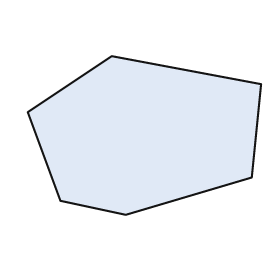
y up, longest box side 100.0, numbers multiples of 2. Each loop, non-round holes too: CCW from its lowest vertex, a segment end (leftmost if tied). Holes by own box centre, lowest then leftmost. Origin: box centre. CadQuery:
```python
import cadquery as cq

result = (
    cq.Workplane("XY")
    .moveTo(-8.0, -34.0)
    .lineTo(46.0, -18.0)
    .lineTo(50.0, 22.0)
    .lineTo(-14.0, 34.0)
    .lineTo(-50.0, 10.0)
    .lineTo(-36.0, -28.0)
    .close()
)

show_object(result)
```